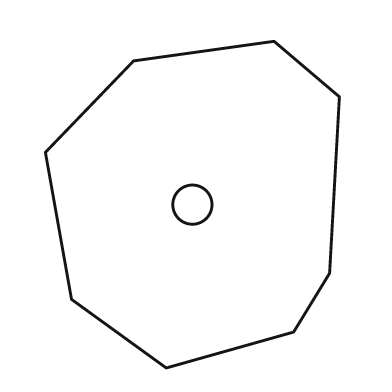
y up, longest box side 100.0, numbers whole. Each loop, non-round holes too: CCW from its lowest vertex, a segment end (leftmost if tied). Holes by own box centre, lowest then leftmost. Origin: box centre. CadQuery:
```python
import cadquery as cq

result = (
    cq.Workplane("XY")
    .moveTo(-8.0, -50.0)
    .lineTo(31.0, -39.0)
    .lineTo(42.0, -21.0)
    .lineTo(45.0, 33.0)
    .lineTo(25.0, 50.0)
    .lineTo(-18.0, 44.0)
    .lineTo(-45.0, 16.0)
    .lineTo(-37.0, -29.0)
    .close()
    .moveTo(0.0, 0.0)
    .circle(6.0)
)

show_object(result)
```